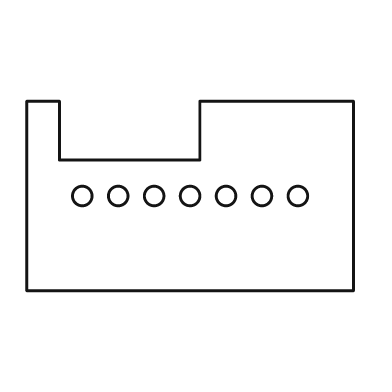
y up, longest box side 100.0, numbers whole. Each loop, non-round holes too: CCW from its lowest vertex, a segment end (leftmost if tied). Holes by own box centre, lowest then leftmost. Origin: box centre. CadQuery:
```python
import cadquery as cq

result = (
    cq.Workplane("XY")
    .moveTo(-50.0, -29.0)
    .lineTo(50.0, -29.0)
    .lineTo(50.0, 29.0)
    .lineTo(3.0, 29.0)
    .lineTo(3.0, 11.0)
    .lineTo(-40.0, 11.0)
    .lineTo(-40.0, 29.0)
    .lineTo(-50.0, 29.0)
    .close()
    .moveTo(-33.0, 0.0)
    .circle(3.0)
    .moveTo(-22.0, 0.0)
    .circle(3.0)
    .moveTo(-11.0, 0.0)
    .circle(3.0)
    .moveTo(0.0, 0.0)
    .circle(3.0)
    .moveTo(11.0, 0.0)
    .circle(3.0)
    .moveTo(22.0, 0.0)
    .circle(3.0)
    .moveTo(33.0, 0.0)
    .circle(3.0)
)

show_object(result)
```